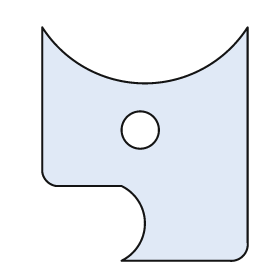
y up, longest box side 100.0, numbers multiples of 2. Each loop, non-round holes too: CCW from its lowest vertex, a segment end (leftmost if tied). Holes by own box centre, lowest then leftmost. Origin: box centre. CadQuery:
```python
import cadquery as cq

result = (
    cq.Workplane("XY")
    .moveTo(-10.0, -50.0)
    .lineTo(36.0, -50.0)
    .threePointArc((42.0, -48.0), (44.0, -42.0))
    .lineTo(44.0, 50.0)
    .threePointArc((0.0, 26.0), (-44.0, 50.0))
    .lineTo(-44.0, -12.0)
    .threePointArc((-42.0, -16.0), (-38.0, -18.0))
    .lineTo(-10.0, -18.0)
    .threePointArc((0.0, -34.0), (-10.0, -50.0))
    .close()
    .moveTo(-2.0, 6.0)
    .circle(8.0)
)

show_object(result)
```